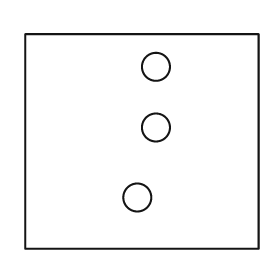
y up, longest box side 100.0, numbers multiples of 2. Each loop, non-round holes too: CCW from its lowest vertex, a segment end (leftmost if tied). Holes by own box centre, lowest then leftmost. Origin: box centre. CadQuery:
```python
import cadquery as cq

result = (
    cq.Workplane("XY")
    .moveTo(-50.0, -46.0)
    .lineTo(50.0, -46.0)
    .lineTo(50.0, 46.0)
    .lineTo(-50.0, 46.0)
    .close()
    .moveTo(-2.0, -24.0)
    .circle(6.0)
    .moveTo(6.0, 6.0)
    .circle(6.0)
    .moveTo(6.0, 32.0)
    .circle(6.0)
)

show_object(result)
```